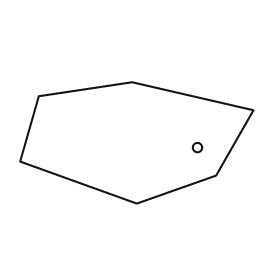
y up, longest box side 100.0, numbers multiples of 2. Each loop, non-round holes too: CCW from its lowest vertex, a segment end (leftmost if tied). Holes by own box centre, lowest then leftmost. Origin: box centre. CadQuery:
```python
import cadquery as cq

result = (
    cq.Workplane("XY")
    .moveTo(0.0, -26.0)
    .lineTo(34.0, -14.0)
    .lineTo(50.0, 14.0)
    .lineTo(-2.0, 26.0)
    .lineTo(-42.0, 20.0)
    .lineTo(-50.0, -8.0)
    .close()
    .moveTo(26.0, -2.0)
    .circle(2.0)
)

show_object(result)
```